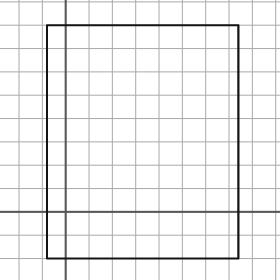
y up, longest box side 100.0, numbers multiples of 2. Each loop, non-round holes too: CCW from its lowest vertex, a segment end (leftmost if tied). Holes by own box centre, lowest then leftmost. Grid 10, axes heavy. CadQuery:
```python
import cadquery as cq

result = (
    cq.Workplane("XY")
    .moveTo(-8.0, -20.0)
    .lineTo(74.0, -20.0)
    .lineTo(74.0, 80.0)
    .lineTo(-8.0, 80.0)
    .close()
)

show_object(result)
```